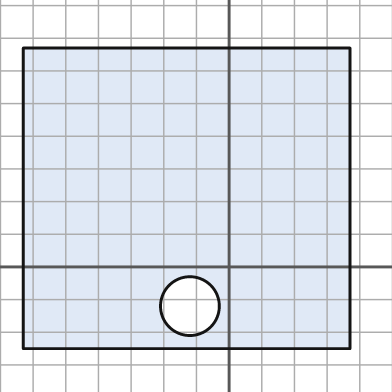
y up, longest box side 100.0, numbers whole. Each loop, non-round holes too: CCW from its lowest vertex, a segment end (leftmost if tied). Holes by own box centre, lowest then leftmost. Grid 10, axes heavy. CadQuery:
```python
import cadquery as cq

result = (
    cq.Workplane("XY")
    .moveTo(-63.0, -25.0)
    .lineTo(37.0, -25.0)
    .lineTo(37.0, 67.0)
    .lineTo(-63.0, 67.0)
    .close()
    .moveTo(-12.0, -12.0)
    .circle(9.0)
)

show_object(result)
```